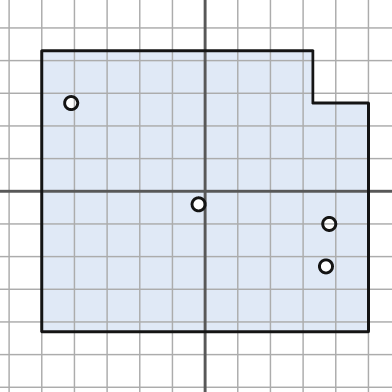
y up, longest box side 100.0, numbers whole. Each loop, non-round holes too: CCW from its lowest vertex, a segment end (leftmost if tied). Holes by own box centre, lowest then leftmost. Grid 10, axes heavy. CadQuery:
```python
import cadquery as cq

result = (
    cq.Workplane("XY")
    .moveTo(-50.0, -43.0)
    .lineTo(50.0, -43.0)
    .lineTo(50.0, 27.0)
    .lineTo(33.0, 27.0)
    .lineTo(33.0, 43.0)
    .lineTo(-50.0, 43.0)
    .close()
    .moveTo(37.0, -23.0)
    .circle(2.0)
    .moveTo(38.0, -10.0)
    .circle(2.0)
    .moveTo(-2.0, -4.0)
    .circle(2.0)
    .moveTo(-41.0, 27.0)
    .circle(2.0)
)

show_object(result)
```